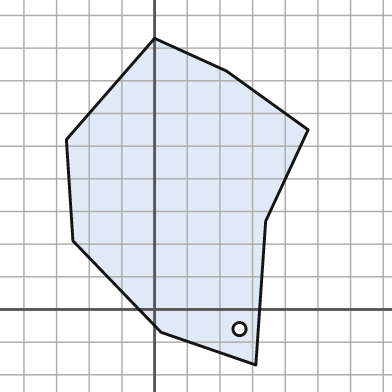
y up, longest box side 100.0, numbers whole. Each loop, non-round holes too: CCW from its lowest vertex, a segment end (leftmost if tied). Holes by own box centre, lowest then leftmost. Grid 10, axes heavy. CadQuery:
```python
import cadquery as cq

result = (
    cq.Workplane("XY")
    .moveTo(31.0, -17.0)
    .lineTo(34.0, 27.0)
    .lineTo(47.0, 55.0)
    .lineTo(22.0, 73.0)
    .lineTo(0.0, 83.0)
    .lineTo(-27.0, 52.0)
    .lineTo(-25.0, 21.0)
    .lineTo(2.0, -7.0)
    .close()
    .moveTo(26.0, -6.0)
    .circle(2.0)
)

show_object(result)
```